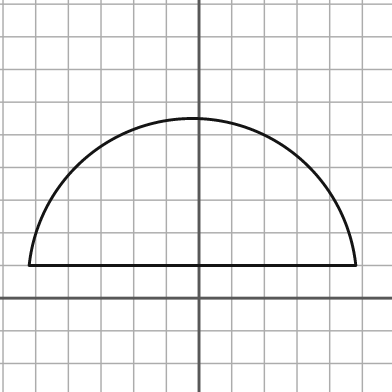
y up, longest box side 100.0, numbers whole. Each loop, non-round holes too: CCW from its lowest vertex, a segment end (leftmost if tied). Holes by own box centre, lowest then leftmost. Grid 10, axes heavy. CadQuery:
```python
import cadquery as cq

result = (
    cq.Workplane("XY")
    .moveTo(-52.0, 10.0)
    .lineTo(48.0, 10.0)
    .threePointArc((-2.0, 55.0), (-52.0, 10.0))
    .close()
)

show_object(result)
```